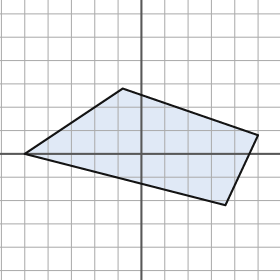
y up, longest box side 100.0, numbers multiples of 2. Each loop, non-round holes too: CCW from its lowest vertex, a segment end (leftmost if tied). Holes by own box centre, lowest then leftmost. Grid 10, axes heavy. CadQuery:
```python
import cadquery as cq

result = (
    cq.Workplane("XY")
    .moveTo(36.0, -22.0)
    .lineTo(50.0, 8.0)
    .lineTo(-8.0, 28.0)
    .lineTo(-50.0, 0.0)
    .close()
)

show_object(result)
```